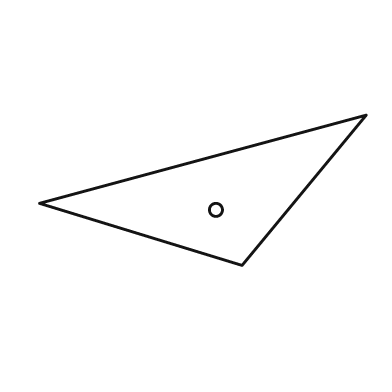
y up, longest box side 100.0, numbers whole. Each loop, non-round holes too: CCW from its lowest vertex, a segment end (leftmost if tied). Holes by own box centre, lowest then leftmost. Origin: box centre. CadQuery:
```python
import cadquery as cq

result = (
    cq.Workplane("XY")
    .moveTo(12.0, -23.0)
    .lineTo(50.0, 23.0)
    .lineTo(-50.0, -4.0)
    .close()
    .moveTo(4.0, -6.0)
    .circle(2.0)
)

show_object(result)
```